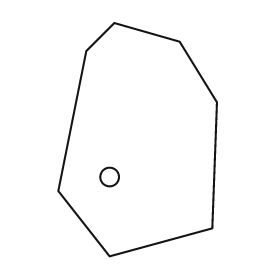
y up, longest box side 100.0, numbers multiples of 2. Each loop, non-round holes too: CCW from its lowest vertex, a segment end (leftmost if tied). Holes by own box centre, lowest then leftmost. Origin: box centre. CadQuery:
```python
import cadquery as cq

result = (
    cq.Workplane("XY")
    .moveTo(-12.0, -50.0)
    .lineTo(32.0, -38.0)
    .lineTo(34.0, 16.0)
    .lineTo(18.0, 42.0)
    .lineTo(-10.0, 50.0)
    .lineTo(-22.0, 38.0)
    .lineTo(-34.0, -22.0)
    .close()
    .moveTo(-12.0, -16.0)
    .circle(4.0)
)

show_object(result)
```